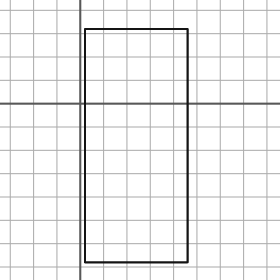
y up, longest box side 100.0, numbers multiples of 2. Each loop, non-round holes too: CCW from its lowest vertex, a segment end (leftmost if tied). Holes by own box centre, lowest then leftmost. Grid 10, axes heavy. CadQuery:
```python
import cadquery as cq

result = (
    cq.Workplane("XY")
    .moveTo(2.0, -68.0)
    .lineTo(46.0, -68.0)
    .lineTo(46.0, 32.0)
    .lineTo(2.0, 32.0)
    .close()
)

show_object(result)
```